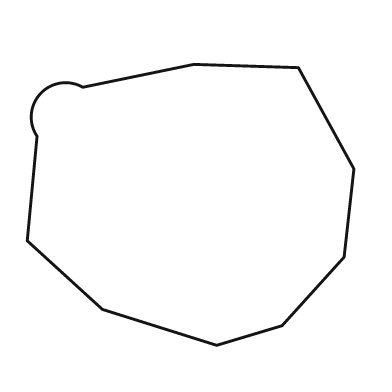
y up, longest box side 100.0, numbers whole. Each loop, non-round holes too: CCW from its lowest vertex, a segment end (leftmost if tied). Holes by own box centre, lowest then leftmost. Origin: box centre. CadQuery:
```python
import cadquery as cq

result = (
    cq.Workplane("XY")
    .moveTo(8.0, -43.0)
    .lineTo(28.0, -37.0)
    .lineTo(47.0, -16.0)
    .lineTo(50.0, 11.0)
    .lineTo(33.0, 42.0)
    .lineTo(1.0, 43.0)
    .lineTo(-33.0, 36.0)
    .threePointArc((-46.0, 34.0), (-47.0, 21.0))
    .lineTo(-50.0, -11.0)
    .lineTo(-27.0, -32.0)
    .close()
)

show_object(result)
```